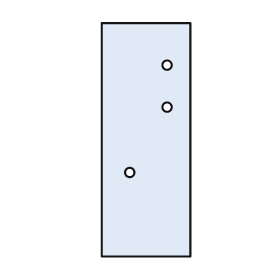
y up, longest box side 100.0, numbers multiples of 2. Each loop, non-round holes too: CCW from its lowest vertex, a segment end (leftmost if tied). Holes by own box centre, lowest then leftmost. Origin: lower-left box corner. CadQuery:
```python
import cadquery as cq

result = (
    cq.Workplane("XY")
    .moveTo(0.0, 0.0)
    .lineTo(38.0, 0.0)
    .lineTo(38.0, 100.0)
    .lineTo(0.0, 100.0)
    .close()
    .moveTo(12.0, 36.0)
    .circle(2.0)
    .moveTo(28.0, 64.0)
    .circle(2.0)
    .moveTo(28.0, 82.0)
    .circle(2.0)
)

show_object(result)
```